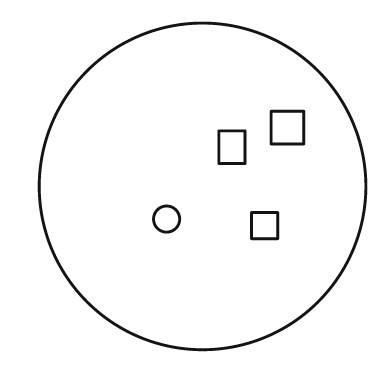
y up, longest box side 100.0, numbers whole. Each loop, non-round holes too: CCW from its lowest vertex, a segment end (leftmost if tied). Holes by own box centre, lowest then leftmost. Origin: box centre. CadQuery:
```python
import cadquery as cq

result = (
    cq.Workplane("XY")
    .moveTo(0.0, 0.0)
    .circle(50.0)
    .moveTo(15.0, -16.0)
    .lineTo(23.0, -16.0)
    .lineTo(23.0, -8.0)
    .lineTo(15.0, -8.0)
    .close()
    .moveTo(-11.0, -10.0)
    .circle(4.0)
    .moveTo(5.0, 7.0)
    .lineTo(13.0, 7.0)
    .lineTo(13.0, 17.0)
    .lineTo(5.0, 17.0)
    .close()
    .moveTo(21.0, 13.0)
    .lineTo(31.0, 13.0)
    .lineTo(31.0, 23.0)
    .lineTo(21.0, 23.0)
    .close()
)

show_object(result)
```